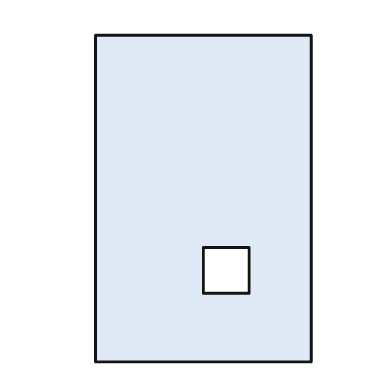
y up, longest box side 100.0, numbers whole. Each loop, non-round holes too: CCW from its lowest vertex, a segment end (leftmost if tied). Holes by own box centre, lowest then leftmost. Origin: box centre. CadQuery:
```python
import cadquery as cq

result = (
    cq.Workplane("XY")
    .moveTo(-33.0, -50.0)
    .lineTo(33.0, -50.0)
    .lineTo(33.0, 50.0)
    .lineTo(-33.0, 50.0)
    .close()
    .moveTo(0.0, -29.0)
    .lineTo(14.0, -29.0)
    .lineTo(14.0, -15.0)
    .lineTo(0.0, -15.0)
    .close()
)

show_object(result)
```